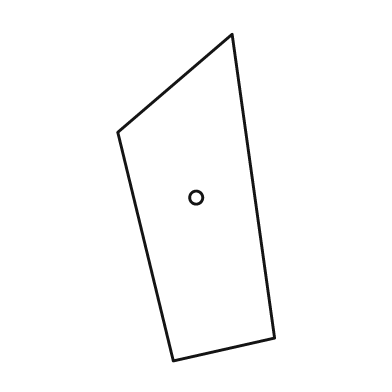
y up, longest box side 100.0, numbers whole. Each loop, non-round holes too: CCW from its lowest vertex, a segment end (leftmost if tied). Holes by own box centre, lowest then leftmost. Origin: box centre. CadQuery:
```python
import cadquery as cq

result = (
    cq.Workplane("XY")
    .moveTo(-7.0, -50.0)
    .lineTo(24.0, -43.0)
    .lineTo(11.0, 50.0)
    .lineTo(-24.0, 20.0)
    .close()
    .moveTo(0.0, 0.0)
    .circle(2.0)
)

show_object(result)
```